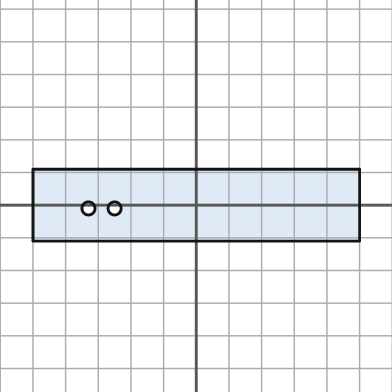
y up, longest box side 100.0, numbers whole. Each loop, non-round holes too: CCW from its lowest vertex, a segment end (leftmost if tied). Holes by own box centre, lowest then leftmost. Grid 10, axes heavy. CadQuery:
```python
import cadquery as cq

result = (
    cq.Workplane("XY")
    .moveTo(-50.0, -11.0)
    .lineTo(50.0, -11.0)
    .lineTo(50.0, 11.0)
    .lineTo(-50.0, 11.0)
    .close()
    .moveTo(-33.0, -1.0)
    .circle(2.0)
    .moveTo(-25.0, -1.0)
    .circle(2.0)
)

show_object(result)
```